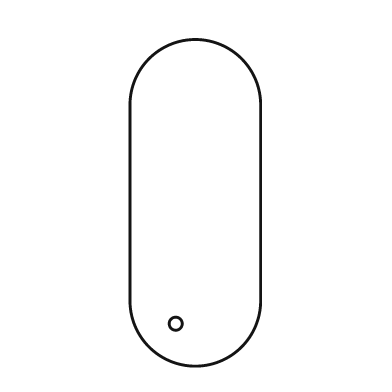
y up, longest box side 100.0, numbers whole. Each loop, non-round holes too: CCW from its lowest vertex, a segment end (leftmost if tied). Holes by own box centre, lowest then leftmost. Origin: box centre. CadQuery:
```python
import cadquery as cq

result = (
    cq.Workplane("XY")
    .moveTo(-20.0, -30.0)
    .threePointArc((0.0, -50.0), (20.0, -30.0))
    .lineTo(20.0, 30.0)
    .threePointArc((0.0, 50.0), (-20.0, 30.0))
    .close()
    .moveTo(-6.0, -37.0)
    .circle(2.0)
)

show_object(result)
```